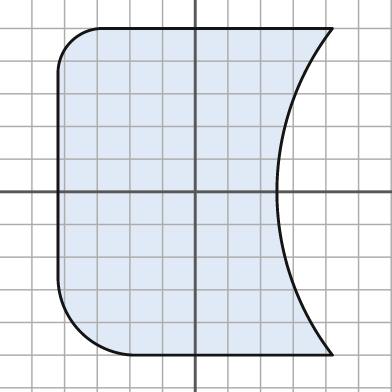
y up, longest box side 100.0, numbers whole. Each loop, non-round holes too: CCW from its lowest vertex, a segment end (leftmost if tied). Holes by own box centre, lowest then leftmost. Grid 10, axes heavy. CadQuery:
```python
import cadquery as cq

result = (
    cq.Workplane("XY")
    .moveTo(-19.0, -50.0)
    .lineTo(42.0, -50.0)
    .threePointArc((25.0, 0.0), (42.0, 50.0))
    .lineTo(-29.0, 50.0)
    .threePointArc((-38.0, 46.0), (-42.0, 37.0))
    .lineTo(-42.0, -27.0)
    .threePointArc((-35.0, -43.0), (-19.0, -50.0))
    .close()
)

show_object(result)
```